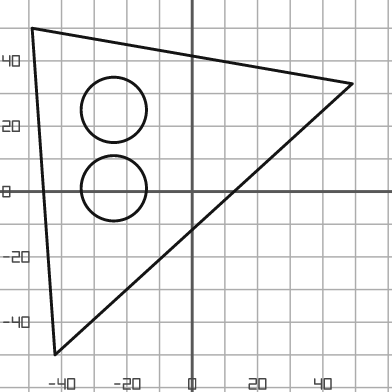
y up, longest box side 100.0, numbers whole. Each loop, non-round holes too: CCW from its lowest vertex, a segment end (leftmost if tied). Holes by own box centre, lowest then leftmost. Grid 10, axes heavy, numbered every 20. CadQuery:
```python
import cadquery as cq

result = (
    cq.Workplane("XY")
    .moveTo(-42.0, -50.0)
    .lineTo(49.0, 33.0)
    .lineTo(-49.0, 50.0)
    .close()
    .moveTo(-24.0, 1.0)
    .circle(10.0)
    .moveTo(-24.0, 25.0)
    .circle(10.0)
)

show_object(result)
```